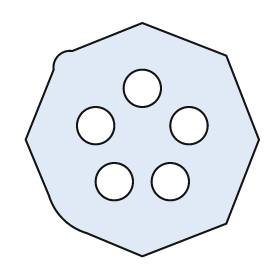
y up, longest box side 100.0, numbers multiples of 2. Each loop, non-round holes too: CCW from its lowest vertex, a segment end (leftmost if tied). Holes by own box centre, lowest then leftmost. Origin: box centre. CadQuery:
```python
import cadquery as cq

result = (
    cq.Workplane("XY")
    .moveTo(0.0, -50.0)
    .lineTo(36.0, -36.0)
    .lineTo(50.0, 0.0)
    .lineTo(36.0, 36.0)
    .lineTo(0.0, 50.0)
    .lineTo(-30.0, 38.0)
    .threePointArc((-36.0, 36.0), (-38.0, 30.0))
    .lineTo(-50.0, 0.0)
    .lineTo(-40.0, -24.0)
    .threePointArc((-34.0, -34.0), (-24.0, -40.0))
    .close()
    .moveTo(-12.0, -18.0)
    .circle(8.0)
    .moveTo(12.0, -18.0)
    .circle(8.0)
    .moveTo(-20.0, 6.0)
    .circle(8.0)
    .moveTo(20.0, 6.0)
    .circle(8.0)
    .moveTo(0.0, 22.0)
    .circle(8.0)
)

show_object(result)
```